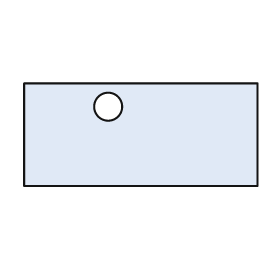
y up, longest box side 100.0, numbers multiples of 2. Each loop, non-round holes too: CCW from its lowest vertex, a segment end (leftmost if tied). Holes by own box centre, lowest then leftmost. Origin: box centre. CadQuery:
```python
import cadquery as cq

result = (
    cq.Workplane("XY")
    .moveTo(-50.0, -22.0)
    .lineTo(50.0, -22.0)
    .lineTo(50.0, 22.0)
    .lineTo(-50.0, 22.0)
    .close()
    .moveTo(-14.0, 12.0)
    .circle(6.0)
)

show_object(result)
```